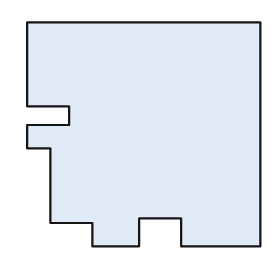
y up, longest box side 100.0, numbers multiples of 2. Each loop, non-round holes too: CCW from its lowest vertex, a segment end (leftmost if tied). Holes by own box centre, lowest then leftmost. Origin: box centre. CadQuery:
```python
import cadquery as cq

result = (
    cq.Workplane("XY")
    .moveTo(-22.0, -48.0)
    .lineTo(-2.0, -48.0)
    .lineTo(-2.0, -36.0)
    .lineTo(16.0, -36.0)
    .lineTo(16.0, -48.0)
    .lineTo(50.0, -48.0)
    .lineTo(50.0, 48.0)
    .lineTo(-50.0, 48.0)
    .lineTo(-50.0, 12.0)
    .lineTo(-32.0, 12.0)
    .lineTo(-32.0, 4.0)
    .lineTo(-50.0, 4.0)
    .lineTo(-50.0, -6.0)
    .lineTo(-40.0, -6.0)
    .lineTo(-40.0, -38.0)
    .lineTo(-22.0, -38.0)
    .close()
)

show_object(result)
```